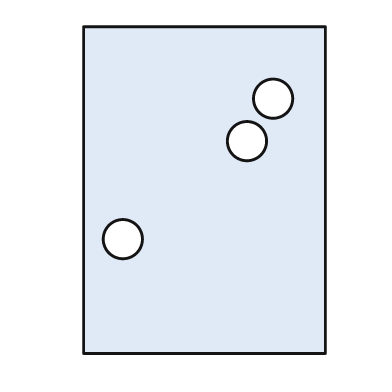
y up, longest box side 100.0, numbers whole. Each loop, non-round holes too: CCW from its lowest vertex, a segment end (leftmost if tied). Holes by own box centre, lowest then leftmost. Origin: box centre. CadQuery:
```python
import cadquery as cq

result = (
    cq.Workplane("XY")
    .moveTo(-37.0, -50.0)
    .lineTo(37.0, -50.0)
    .lineTo(37.0, 50.0)
    .lineTo(-37.0, 50.0)
    .close()
    .moveTo(-25.0, -15.0)
    .circle(6.0)
    .moveTo(13.0, 15.0)
    .circle(6.0)
    .moveTo(21.0, 28.0)
    .circle(6.0)
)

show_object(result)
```